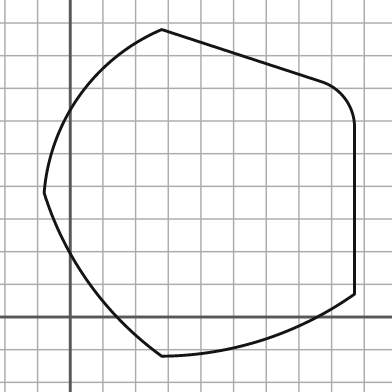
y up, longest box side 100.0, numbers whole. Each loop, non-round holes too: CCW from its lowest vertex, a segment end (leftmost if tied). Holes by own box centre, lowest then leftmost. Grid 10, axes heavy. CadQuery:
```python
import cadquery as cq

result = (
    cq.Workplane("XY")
    .moveTo(28.0, -12.0)
    .threePointArc((59.0, -7.0), (87.0, 7.0))
    .lineTo(87.0, 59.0)
    .threePointArc((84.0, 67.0), (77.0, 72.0))
    .lineTo(28.0, 88.0)
    .threePointArc((3.0, 68.0), (-8.0, 38.0))
    .threePointArc((6.0, 10.0), (28.0, -12.0))
    .close()
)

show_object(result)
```